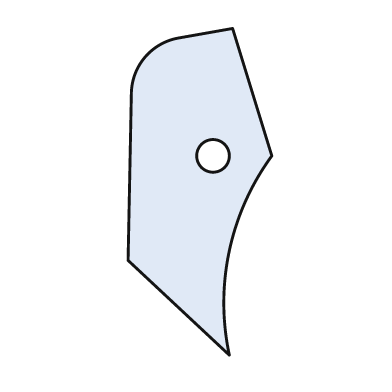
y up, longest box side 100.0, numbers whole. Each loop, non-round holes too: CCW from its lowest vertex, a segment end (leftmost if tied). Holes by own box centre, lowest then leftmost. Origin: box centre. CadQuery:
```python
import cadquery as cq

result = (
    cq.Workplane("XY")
    .moveTo(9.0, -50.0)
    .threePointArc((9.0, -18.0), (22.0, 11.0))
    .lineTo(10.0, 50.0)
    .lineTo(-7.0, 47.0)
    .threePointArc((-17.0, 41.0), (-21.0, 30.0))
    .lineTo(-22.0, -21.0)
    .close()
    .moveTo(4.0, 11.0)
    .circle(5.0)
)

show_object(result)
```